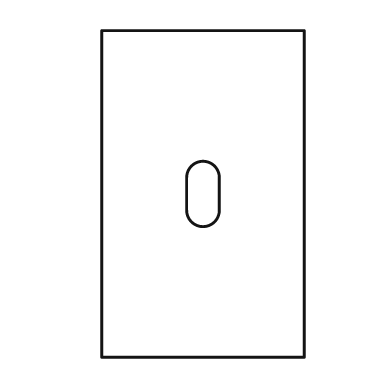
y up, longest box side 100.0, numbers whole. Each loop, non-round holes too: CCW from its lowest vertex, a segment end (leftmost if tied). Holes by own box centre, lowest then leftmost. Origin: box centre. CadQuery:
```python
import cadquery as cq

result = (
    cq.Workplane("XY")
    .moveTo(-31.0, -50.0)
    .lineTo(31.0, -50.0)
    .lineTo(31.0, 50.0)
    .lineTo(-31.0, 50.0)
    .close()
    .moveTo(-5.0, -5.0)
    .threePointArc((0.0, -10.0), (5.0, -5.0))
    .lineTo(5.0, 5.0)
    .threePointArc((0.0, 10.0), (-5.0, 5.0))
    .close()
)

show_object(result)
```